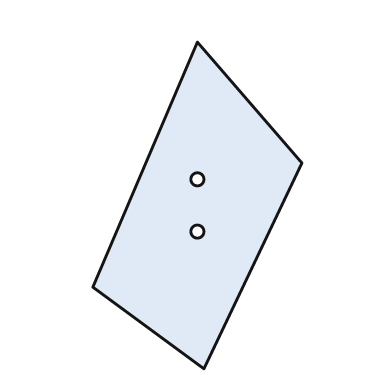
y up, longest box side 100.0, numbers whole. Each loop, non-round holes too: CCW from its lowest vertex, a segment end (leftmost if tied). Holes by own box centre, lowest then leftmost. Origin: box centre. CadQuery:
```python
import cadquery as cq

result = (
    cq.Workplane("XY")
    .moveTo(2.0, -50.0)
    .lineTo(32.0, 13.0)
    .lineTo(0.0, 50.0)
    .lineTo(-32.0, -25.0)
    .close()
    .moveTo(0.0, -8.0)
    .circle(2.0)
    .moveTo(0.0, 8.0)
    .circle(2.0)
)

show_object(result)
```